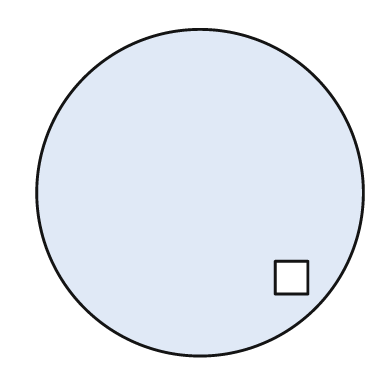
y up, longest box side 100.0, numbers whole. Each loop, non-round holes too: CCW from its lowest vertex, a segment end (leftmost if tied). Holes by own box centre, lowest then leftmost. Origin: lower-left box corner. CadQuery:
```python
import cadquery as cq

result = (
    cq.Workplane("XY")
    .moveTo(50.0, 50.0)
    .circle(50.0)
    .moveTo(73.0, 19.0)
    .lineTo(83.0, 19.0)
    .lineTo(83.0, 29.0)
    .lineTo(73.0, 29.0)
    .close()
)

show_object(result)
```